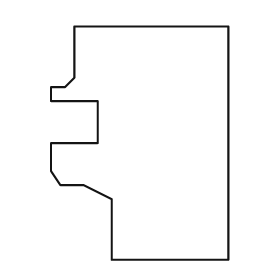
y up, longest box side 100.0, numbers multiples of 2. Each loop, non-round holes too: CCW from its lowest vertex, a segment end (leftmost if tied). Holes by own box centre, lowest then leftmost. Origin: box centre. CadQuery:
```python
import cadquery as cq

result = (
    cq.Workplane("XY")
    .moveTo(-12.0, -50.0)
    .lineTo(38.0, -50.0)
    .lineTo(38.0, 50.0)
    .lineTo(-28.0, 50.0)
    .lineTo(-28.0, 28.0)
    .lineTo(-32.0, 24.0)
    .lineTo(-38.0, 24.0)
    .lineTo(-38.0, 18.0)
    .lineTo(-18.0, 18.0)
    .lineTo(-18.0, 0.0)
    .lineTo(-38.0, 0.0)
    .lineTo(-38.0, -12.0)
    .lineTo(-34.0, -18.0)
    .lineTo(-24.0, -18.0)
    .lineTo(-12.0, -24.0)
    .close()
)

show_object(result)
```